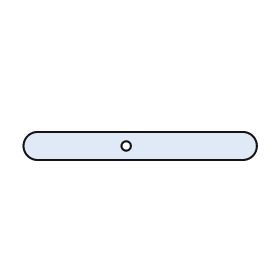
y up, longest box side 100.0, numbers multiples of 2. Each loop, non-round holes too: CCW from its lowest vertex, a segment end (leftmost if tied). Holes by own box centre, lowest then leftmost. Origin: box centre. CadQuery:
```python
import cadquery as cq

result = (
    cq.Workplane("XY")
    .moveTo(-44.0, -6.0)
    .lineTo(44.0, -6.0)
    .threePointArc((50.0, 0.0), (44.0, 6.0))
    .lineTo(-44.0, 6.0)
    .threePointArc((-50.0, 0.0), (-44.0, -6.0))
    .close()
    .moveTo(-6.0, 0.0)
    .circle(2.0)
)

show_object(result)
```